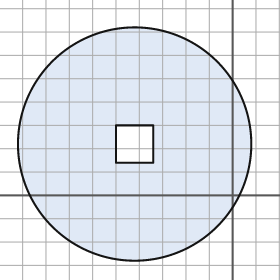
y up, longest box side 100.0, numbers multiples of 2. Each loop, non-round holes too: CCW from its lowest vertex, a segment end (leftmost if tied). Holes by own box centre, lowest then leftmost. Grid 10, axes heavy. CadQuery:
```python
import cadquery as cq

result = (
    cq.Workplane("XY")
    .moveTo(-42.0, 22.0)
    .circle(50.0)
    .moveTo(-50.0, 14.0)
    .lineTo(-34.0, 14.0)
    .lineTo(-34.0, 30.0)
    .lineTo(-50.0, 30.0)
    .close()
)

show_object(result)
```